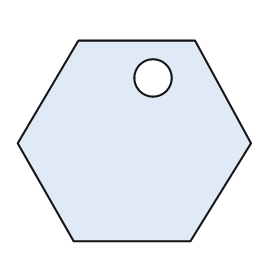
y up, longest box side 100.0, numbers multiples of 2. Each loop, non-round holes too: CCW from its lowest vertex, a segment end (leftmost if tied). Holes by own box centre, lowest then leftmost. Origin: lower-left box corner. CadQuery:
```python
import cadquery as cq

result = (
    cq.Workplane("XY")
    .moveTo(24.0, 0.0)
    .lineTo(74.0, 0.0)
    .lineTo(100.0, 42.0)
    .lineTo(76.0, 86.0)
    .lineTo(26.0, 86.0)
    .lineTo(0.0, 42.0)
    .close()
    .moveTo(58.0, 70.0)
    .circle(8.0)
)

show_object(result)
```